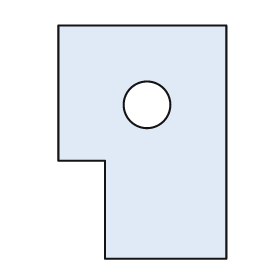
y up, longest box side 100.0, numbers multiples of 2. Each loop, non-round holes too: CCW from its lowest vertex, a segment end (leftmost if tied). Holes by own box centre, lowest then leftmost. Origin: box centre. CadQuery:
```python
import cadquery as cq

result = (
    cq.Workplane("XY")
    .moveTo(-16.0, -50.0)
    .lineTo(36.0, -50.0)
    .lineTo(36.0, 50.0)
    .lineTo(-36.0, 50.0)
    .lineTo(-36.0, -8.0)
    .lineTo(-16.0, -8.0)
    .close()
    .moveTo(2.0, 16.0)
    .circle(10.0)
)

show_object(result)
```